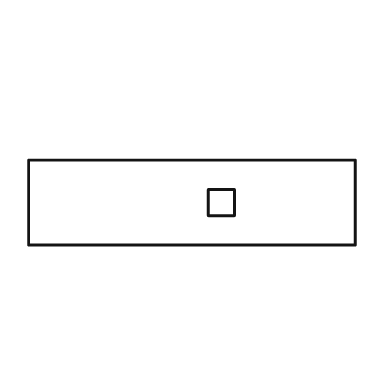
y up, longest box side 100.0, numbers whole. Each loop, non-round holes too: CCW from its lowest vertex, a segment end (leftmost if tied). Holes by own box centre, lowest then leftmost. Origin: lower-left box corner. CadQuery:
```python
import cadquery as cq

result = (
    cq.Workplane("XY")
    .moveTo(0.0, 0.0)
    .lineTo(100.0, 0.0)
    .lineTo(100.0, 26.0)
    .lineTo(0.0, 26.0)
    .close()
    .moveTo(55.0, 9.0)
    .lineTo(63.0, 9.0)
    .lineTo(63.0, 17.0)
    .lineTo(55.0, 17.0)
    .close()
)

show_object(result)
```